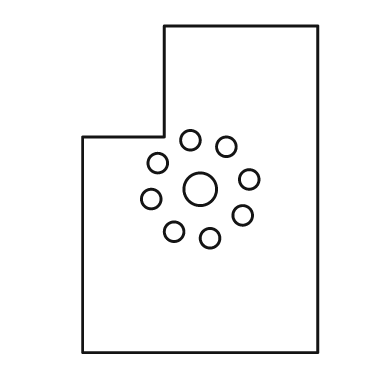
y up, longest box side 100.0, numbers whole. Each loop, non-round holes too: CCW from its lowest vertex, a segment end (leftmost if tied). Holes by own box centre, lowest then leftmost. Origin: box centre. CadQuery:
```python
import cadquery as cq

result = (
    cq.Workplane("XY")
    .moveTo(-36.0, -50.0)
    .lineTo(36.0, -50.0)
    .lineTo(36.0, 50.0)
    .lineTo(-11.0, 50.0)
    .lineTo(-11.0, 16.0)
    .lineTo(-36.0, 16.0)
    .close()
    .moveTo(3.0, -15.0)
    .circle(3.0)
    .moveTo(-8.0, -13.0)
    .circle(3.0)
    .moveTo(13.0, -8.0)
    .circle(3.0)
    .moveTo(-15.0, -3.0)
    .circle(3.0)
    .moveTo(0.0, 0.0)
    .circle(5.0)
    .moveTo(15.0, 3.0)
    .circle(3.0)
    .moveTo(-13.0, 8.0)
    .circle(3.0)
    .moveTo(8.0, 13.0)
    .circle(3.0)
    .moveTo(-3.0, 15.0)
    .circle(3.0)
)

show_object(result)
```